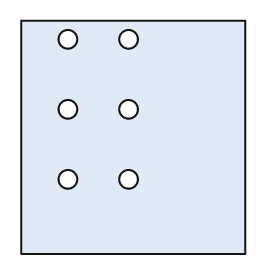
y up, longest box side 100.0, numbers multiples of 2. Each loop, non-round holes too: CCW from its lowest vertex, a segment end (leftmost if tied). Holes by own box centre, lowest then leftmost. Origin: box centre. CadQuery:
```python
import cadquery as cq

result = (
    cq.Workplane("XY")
    .moveTo(-48.0, -50.0)
    .lineTo(48.0, -50.0)
    .lineTo(48.0, 50.0)
    .lineTo(-48.0, 50.0)
    .close()
    .moveTo(-28.0, -18.0)
    .circle(4.0)
    .moveTo(-2.0, -18.0)
    .circle(4.0)
    .moveTo(-28.0, 12.0)
    .circle(4.0)
    .moveTo(-2.0, 12.0)
    .circle(4.0)
    .moveTo(-28.0, 42.0)
    .circle(4.0)
    .moveTo(-2.0, 42.0)
    .circle(4.0)
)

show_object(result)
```